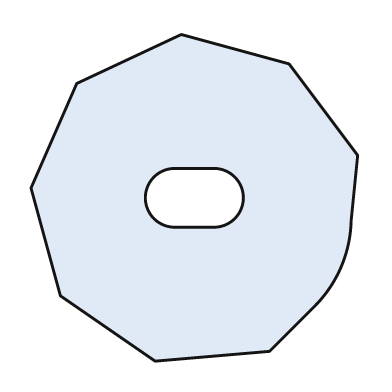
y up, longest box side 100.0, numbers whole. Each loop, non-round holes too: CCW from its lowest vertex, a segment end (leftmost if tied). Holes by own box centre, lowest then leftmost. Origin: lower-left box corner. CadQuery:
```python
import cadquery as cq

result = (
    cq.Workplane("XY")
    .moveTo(38.0, 0.0)
    .lineTo(73.0, 3.0)
    .lineTo(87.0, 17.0)
    .threePointArc((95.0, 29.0), (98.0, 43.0))
    .lineTo(100.0, 63.0)
    .lineTo(79.0, 91.0)
    .lineTo(46.0, 100.0)
    .lineTo(14.0, 85.0)
    .lineTo(0.0, 53.0)
    .lineTo(9.0, 20.0)
    .close()
    .moveTo(44.0, 41.0)
    .lineTo(56.0, 41.0)
    .threePointArc((65.0, 50.0), (56.0, 59.0))
    .lineTo(44.0, 59.0)
    .threePointArc((35.0, 50.0), (44.0, 41.0))
    .close()
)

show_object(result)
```